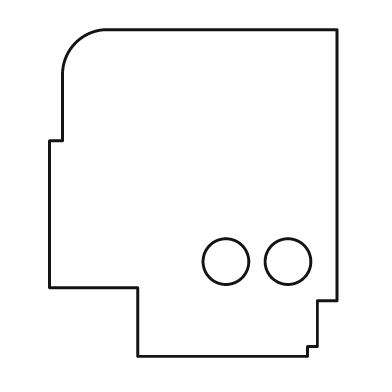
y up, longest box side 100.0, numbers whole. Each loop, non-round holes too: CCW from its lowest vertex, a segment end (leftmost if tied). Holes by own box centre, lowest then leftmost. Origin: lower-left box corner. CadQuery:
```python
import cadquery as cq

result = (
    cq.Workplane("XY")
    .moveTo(27.0, 0.0)
    .lineTo(79.0, 0.0)
    .lineTo(79.0, 3.0)
    .lineTo(82.0, 3.0)
    .lineTo(82.0, 17.0)
    .lineTo(88.0, 17.0)
    .lineTo(88.0, 100.0)
    .lineTo(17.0, 100.0)
    .threePointArc((8.0, 96.0), (4.0, 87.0))
    .lineTo(4.0, 66.0)
    .lineTo(0.0, 66.0)
    .lineTo(0.0, 21.0)
    .lineTo(27.0, 21.0)
    .close()
    .moveTo(54.0, 29.0)
    .circle(7.0)
    .moveTo(73.0, 29.0)
    .circle(7.0)
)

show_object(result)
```